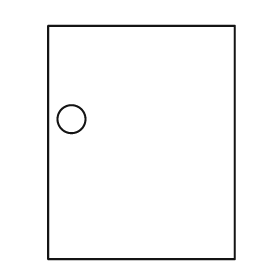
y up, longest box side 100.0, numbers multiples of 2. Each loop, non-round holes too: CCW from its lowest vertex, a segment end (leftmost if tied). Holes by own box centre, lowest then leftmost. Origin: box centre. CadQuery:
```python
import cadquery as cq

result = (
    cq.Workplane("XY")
    .moveTo(-40.0, -50.0)
    .lineTo(40.0, -50.0)
    .lineTo(40.0, 50.0)
    .lineTo(-40.0, 50.0)
    .close()
    .moveTo(-30.0, 10.0)
    .circle(6.0)
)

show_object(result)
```